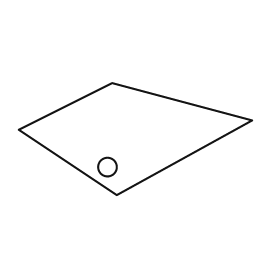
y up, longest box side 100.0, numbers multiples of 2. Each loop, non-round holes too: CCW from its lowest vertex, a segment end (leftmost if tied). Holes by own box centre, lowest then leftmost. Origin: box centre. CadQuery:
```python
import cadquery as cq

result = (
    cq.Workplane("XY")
    .moveTo(-8.0, -24.0)
    .lineTo(50.0, 8.0)
    .lineTo(-10.0, 24.0)
    .lineTo(-50.0, 4.0)
    .close()
    .moveTo(-12.0, -12.0)
    .circle(4.0)
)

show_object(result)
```